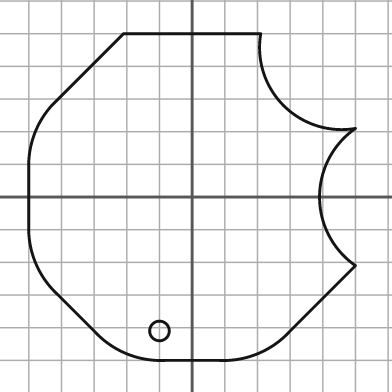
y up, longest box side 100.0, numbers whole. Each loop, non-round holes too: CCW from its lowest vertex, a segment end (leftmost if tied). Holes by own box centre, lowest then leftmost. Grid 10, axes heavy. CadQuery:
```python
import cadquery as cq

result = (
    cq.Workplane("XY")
    .moveTo(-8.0, -50.0)
    .lineTo(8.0, -50.0)
    .threePointArc((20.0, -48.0), (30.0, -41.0))
    .lineTo(50.0, -21.0)
    .threePointArc((39.0, 0.0), (50.0, 21.0))
    .threePointArc((28.0, 28.0), (21.0, 50.0))
    .lineTo(-21.0, 50.0)
    .lineTo(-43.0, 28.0)
    .threePointArc((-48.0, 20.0), (-50.0, 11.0))
    .lineTo(-50.0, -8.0)
    .threePointArc((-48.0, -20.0), (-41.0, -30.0))
    .lineTo(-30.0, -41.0)
    .threePointArc((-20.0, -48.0), (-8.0, -50.0))
    .close()
    .moveTo(-10.0, -41.0)
    .circle(3.0)
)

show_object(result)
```